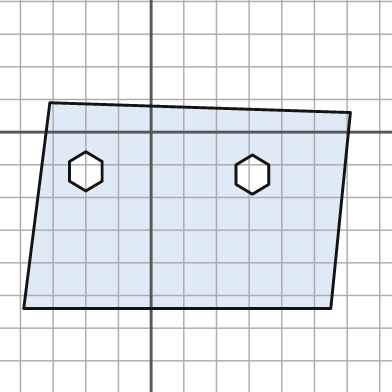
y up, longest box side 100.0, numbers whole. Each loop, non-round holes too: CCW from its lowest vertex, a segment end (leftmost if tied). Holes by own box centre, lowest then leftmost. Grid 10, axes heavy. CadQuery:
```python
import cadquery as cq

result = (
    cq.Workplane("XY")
    .moveTo(-39.0, -54.0)
    .lineTo(55.0, -54.0)
    .lineTo(61.0, 6.0)
    .lineTo(-31.0, 9.0)
    .close()
    .moveTo(31.0, -19.0)
    .lineTo(36.0, -16.0)
    .lineTo(36.0, -10.0)
    .lineTo(31.0, -7.0)
    .lineTo(26.0, -10.0)
    .lineTo(26.0, -16.0)
    .close()
    .moveTo(-20.0, -18.0)
    .lineTo(-15.0, -15.0)
    .lineTo(-15.0, -9.0)
    .lineTo(-20.0, -6.0)
    .lineTo(-25.0, -9.0)
    .lineTo(-25.0, -15.0)
    .close()
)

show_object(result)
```